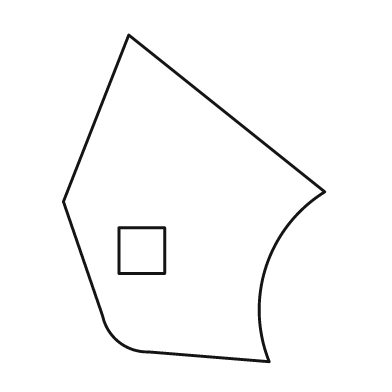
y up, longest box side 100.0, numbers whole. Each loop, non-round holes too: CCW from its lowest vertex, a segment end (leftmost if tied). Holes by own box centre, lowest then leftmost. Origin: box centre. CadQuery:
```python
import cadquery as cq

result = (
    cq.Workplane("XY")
    .moveTo(23.0, -50.0)
    .threePointArc((22.0, -21.0), (40.0, 2.0))
    .lineTo(-20.0, 50.0)
    .lineTo(-40.0, -1.0)
    .lineTo(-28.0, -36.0)
    .threePointArc((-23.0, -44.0), (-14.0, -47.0))
    .close()
    .moveTo(-23.0, -23.0)
    .lineTo(-9.0, -23.0)
    .lineTo(-9.0, -9.0)
    .lineTo(-23.0, -9.0)
    .close()
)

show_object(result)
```